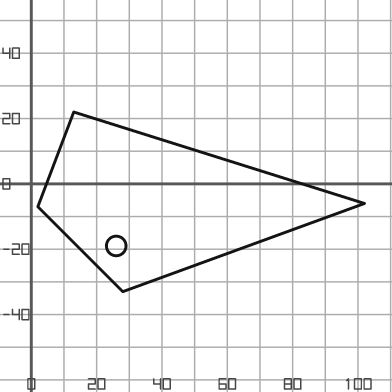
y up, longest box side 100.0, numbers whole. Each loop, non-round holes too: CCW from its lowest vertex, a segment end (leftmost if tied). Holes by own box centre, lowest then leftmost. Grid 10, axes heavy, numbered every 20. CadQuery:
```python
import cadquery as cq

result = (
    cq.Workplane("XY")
    .moveTo(28.0, -33.0)
    .lineTo(102.0, -6.0)
    .lineTo(13.0, 22.0)
    .lineTo(2.0, -7.0)
    .close()
    .moveTo(26.0, -19.0)
    .circle(3.0)
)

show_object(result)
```